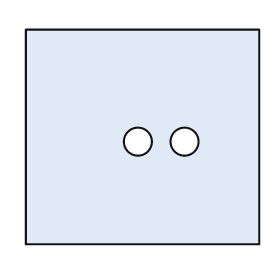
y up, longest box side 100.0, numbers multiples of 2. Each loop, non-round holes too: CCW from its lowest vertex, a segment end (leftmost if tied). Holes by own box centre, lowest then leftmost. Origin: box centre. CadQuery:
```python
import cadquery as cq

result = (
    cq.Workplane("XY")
    .moveTo(-50.0, -46.0)
    .lineTo(50.0, -46.0)
    .lineTo(50.0, 46.0)
    .lineTo(-50.0, 46.0)
    .close()
    .moveTo(-2.0, -2.0)
    .circle(6.0)
    .moveTo(18.0, -2.0)
    .circle(6.0)
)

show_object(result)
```